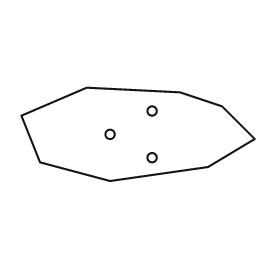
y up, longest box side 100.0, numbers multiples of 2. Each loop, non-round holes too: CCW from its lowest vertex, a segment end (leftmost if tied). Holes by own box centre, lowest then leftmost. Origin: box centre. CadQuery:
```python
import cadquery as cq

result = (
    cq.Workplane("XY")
    .moveTo(-12.0, -20.0)
    .lineTo(30.0, -14.0)
    .lineTo(50.0, -2.0)
    .lineTo(36.0, 12.0)
    .lineTo(18.0, 18.0)
    .lineTo(-22.0, 20.0)
    .lineTo(-50.0, 8.0)
    .lineTo(-42.0, -12.0)
    .close()
    .moveTo(6.0, -10.0)
    .circle(2.0)
    .moveTo(-12.0, 0.0)
    .circle(2.0)
    .moveTo(6.0, 10.0)
    .circle(2.0)
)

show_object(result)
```